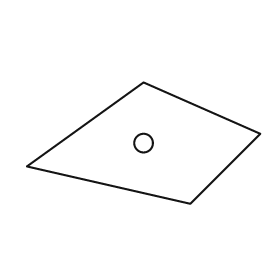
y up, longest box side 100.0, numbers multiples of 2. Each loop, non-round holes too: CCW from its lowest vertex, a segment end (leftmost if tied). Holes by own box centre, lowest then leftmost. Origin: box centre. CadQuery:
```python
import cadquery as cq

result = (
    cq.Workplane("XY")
    .moveTo(20.0, -26.0)
    .lineTo(50.0, 4.0)
    .lineTo(0.0, 26.0)
    .lineTo(-50.0, -10.0)
    .close()
    .moveTo(0.0, 0.0)
    .circle(4.0)
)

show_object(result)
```